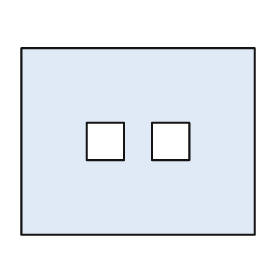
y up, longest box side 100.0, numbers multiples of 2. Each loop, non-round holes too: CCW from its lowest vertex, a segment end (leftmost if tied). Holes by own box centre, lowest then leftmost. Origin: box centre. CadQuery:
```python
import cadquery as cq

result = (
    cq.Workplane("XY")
    .moveTo(-50.0, -40.0)
    .lineTo(50.0, -40.0)
    .lineTo(50.0, 40.0)
    .lineTo(-50.0, 40.0)
    .close()
    .moveTo(-22.0, -8.0)
    .lineTo(-6.0, -8.0)
    .lineTo(-6.0, 8.0)
    .lineTo(-22.0, 8.0)
    .close()
    .moveTo(6.0, -8.0)
    .lineTo(22.0, -8.0)
    .lineTo(22.0, 8.0)
    .lineTo(6.0, 8.0)
    .close()
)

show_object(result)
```